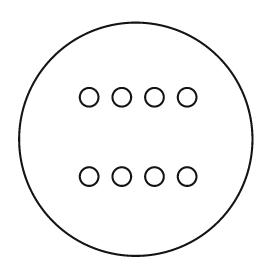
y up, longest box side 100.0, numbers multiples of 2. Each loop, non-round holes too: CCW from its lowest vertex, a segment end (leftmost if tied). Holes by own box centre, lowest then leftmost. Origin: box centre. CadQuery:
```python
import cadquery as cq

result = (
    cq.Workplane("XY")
    .moveTo(0.0, 0.0)
    .circle(50.0)
    .moveTo(-20.0, -16.0)
    .circle(4.0)
    .moveTo(-6.0, -16.0)
    .circle(4.0)
    .moveTo(8.0, -16.0)
    .circle(4.0)
    .moveTo(22.0, -16.0)
    .circle(4.0)
    .moveTo(-20.0, 18.0)
    .circle(4.0)
    .moveTo(-6.0, 18.0)
    .circle(4.0)
    .moveTo(8.0, 18.0)
    .circle(4.0)
    .moveTo(22.0, 18.0)
    .circle(4.0)
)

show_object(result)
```